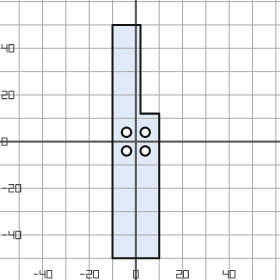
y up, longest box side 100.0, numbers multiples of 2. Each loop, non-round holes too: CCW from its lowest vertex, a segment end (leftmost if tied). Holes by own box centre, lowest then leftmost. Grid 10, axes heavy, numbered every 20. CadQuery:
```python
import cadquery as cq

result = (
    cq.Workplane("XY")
    .moveTo(-10.0, -50.0)
    .lineTo(10.0, -50.0)
    .lineTo(10.0, 12.0)
    .lineTo(2.0, 12.0)
    .lineTo(2.0, 50.0)
    .lineTo(-10.0, 50.0)
    .close()
    .moveTo(-4.0, -4.0)
    .circle(2.0)
    .moveTo(4.0, -4.0)
    .circle(2.0)
    .moveTo(-4.0, 4.0)
    .circle(2.0)
    .moveTo(4.0, 4.0)
    .circle(2.0)
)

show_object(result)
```